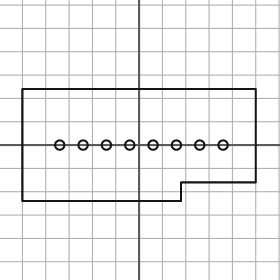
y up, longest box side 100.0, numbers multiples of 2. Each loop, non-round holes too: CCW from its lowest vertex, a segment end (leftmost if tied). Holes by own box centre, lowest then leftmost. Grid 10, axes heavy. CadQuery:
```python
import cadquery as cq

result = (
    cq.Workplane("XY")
    .moveTo(-50.0, -24.0)
    .lineTo(18.0, -24.0)
    .lineTo(18.0, -16.0)
    .lineTo(50.0, -16.0)
    .lineTo(50.0, 24.0)
    .lineTo(-50.0, 24.0)
    .close()
    .moveTo(-34.0, 0.0)
    .circle(2.0)
    .moveTo(-24.0, 0.0)
    .circle(2.0)
    .moveTo(-14.0, 0.0)
    .circle(2.0)
    .moveTo(-4.0, 0.0)
    .circle(2.0)
    .moveTo(6.0, 0.0)
    .circle(2.0)
    .moveTo(16.0, 0.0)
    .circle(2.0)
    .moveTo(26.0, 0.0)
    .circle(2.0)
    .moveTo(36.0, 0.0)
    .circle(2.0)
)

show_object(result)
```